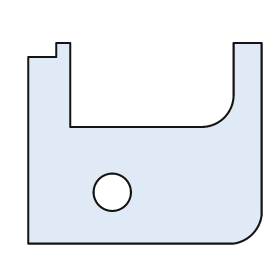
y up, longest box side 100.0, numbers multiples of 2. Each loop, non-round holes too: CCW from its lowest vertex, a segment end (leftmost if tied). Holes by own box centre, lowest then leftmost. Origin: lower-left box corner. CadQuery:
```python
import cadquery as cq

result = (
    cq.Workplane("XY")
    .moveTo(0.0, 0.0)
    .lineTo(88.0, 0.0)
    .threePointArc((96.0, 4.0), (100.0, 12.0))
    .lineTo(100.0, 86.0)
    .lineTo(88.0, 86.0)
    .lineTo(88.0, 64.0)
    .threePointArc((84.0, 54.0), (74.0, 50.0))
    .lineTo(18.0, 50.0)
    .lineTo(18.0, 86.0)
    .lineTo(12.0, 86.0)
    .lineTo(12.0, 80.0)
    .lineTo(0.0, 80.0)
    .close()
    .moveTo(36.0, 22.0)
    .circle(8.0)
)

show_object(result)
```